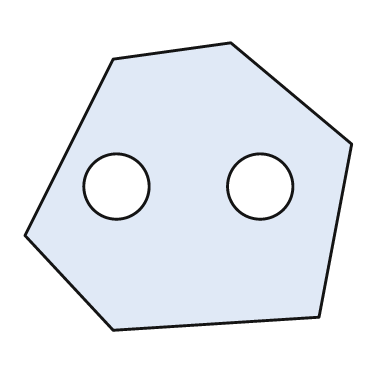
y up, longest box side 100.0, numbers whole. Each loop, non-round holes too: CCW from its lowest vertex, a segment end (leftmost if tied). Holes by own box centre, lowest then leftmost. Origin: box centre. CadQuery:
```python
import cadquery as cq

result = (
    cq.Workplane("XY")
    .moveTo(-23.0, -44.0)
    .lineTo(40.0, -40.0)
    .lineTo(50.0, 13.0)
    .lineTo(13.0, 44.0)
    .lineTo(-23.0, 39.0)
    .lineTo(-50.0, -15.0)
    .close()
    .moveTo(-22.0, 0.0)
    .circle(10.0)
    .moveTo(22.0, 0.0)
    .circle(10.0)
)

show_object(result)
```